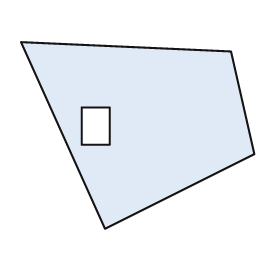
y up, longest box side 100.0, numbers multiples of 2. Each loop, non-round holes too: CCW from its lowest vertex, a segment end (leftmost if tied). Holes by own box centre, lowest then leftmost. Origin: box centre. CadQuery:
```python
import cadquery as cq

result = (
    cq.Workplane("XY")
    .moveTo(-14.0, -40.0)
    .lineTo(50.0, -8.0)
    .lineTo(40.0, 36.0)
    .lineTo(-50.0, 40.0)
    .close()
    .moveTo(-24.0, -4.0)
    .lineTo(-12.0, -4.0)
    .lineTo(-12.0, 12.0)
    .lineTo(-24.0, 12.0)
    .close()
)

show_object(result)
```